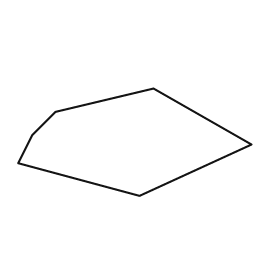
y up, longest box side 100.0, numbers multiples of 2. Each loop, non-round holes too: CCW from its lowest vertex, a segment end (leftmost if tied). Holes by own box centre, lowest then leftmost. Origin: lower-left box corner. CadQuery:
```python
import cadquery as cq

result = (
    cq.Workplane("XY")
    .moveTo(52.0, 0.0)
    .lineTo(100.0, 22.0)
    .lineTo(58.0, 46.0)
    .lineTo(16.0, 36.0)
    .lineTo(6.0, 26.0)
    .lineTo(0.0, 14.0)
    .close()
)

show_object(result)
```